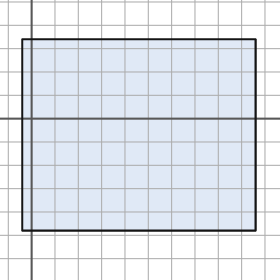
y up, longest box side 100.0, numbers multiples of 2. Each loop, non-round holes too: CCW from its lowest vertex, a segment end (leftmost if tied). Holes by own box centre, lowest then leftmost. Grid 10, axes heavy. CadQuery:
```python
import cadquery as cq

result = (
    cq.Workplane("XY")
    .moveTo(-4.0, -48.0)
    .lineTo(96.0, -48.0)
    .lineTo(96.0, 34.0)
    .lineTo(-4.0, 34.0)
    .close()
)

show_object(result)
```